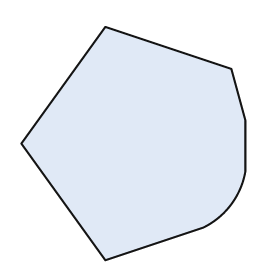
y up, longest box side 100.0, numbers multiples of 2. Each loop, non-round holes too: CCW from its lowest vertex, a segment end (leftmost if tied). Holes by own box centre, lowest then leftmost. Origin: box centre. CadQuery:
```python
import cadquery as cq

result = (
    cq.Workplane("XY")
    .moveTo(-12.0, -50.0)
    .lineTo(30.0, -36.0)
    .threePointArc((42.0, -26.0), (48.0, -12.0))
    .lineTo(48.0, 10.0)
    .lineTo(42.0, 32.0)
    .lineTo(-12.0, 50.0)
    .lineTo(-48.0, 0.0)
    .close()
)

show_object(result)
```